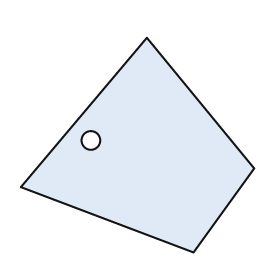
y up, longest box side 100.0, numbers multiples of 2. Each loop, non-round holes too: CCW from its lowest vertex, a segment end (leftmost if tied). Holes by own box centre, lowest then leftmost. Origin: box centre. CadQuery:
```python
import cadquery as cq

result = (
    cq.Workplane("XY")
    .moveTo(24.0, -46.0)
    .lineTo(50.0, -10.0)
    .lineTo(4.0, 46.0)
    .lineTo(-50.0, -18.0)
    .close()
    .moveTo(-20.0, 2.0)
    .circle(4.0)
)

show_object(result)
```